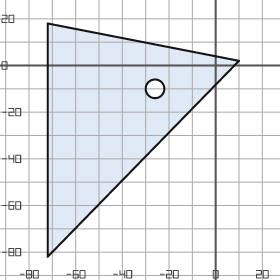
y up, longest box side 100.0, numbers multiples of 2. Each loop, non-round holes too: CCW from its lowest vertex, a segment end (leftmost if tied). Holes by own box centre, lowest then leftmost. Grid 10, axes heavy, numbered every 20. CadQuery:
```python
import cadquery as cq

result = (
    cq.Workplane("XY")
    .moveTo(-72.0, -82.0)
    .lineTo(10.0, 2.0)
    .lineTo(-72.0, 18.0)
    .close()
    .moveTo(-26.0, -10.0)
    .circle(4.0)
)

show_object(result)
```